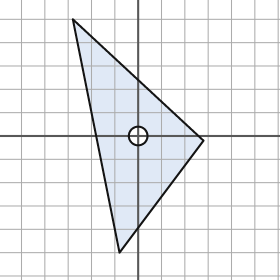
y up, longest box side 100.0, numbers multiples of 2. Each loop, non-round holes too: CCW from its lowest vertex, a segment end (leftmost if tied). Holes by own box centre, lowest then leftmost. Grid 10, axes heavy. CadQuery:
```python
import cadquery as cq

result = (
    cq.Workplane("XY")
    .moveTo(-8.0, -50.0)
    .lineTo(28.0, -2.0)
    .lineTo(-28.0, 50.0)
    .close()
    .moveTo(0.0, 0.0)
    .circle(4.0)
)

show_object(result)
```